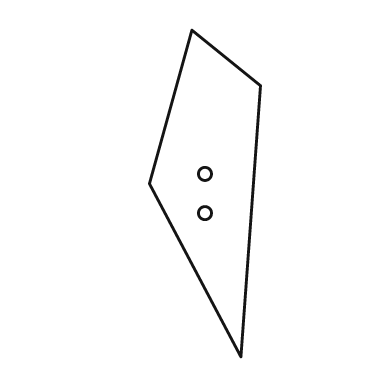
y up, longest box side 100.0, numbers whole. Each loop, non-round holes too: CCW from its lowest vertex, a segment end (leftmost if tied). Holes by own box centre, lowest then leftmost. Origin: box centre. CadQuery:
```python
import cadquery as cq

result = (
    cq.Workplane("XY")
    .moveTo(11.0, -50.0)
    .lineTo(17.0, 33.0)
    .lineTo(-4.0, 50.0)
    .lineTo(-17.0, 3.0)
    .close()
    .moveTo(0.0, -6.0)
    .circle(2.0)
    .moveTo(0.0, 6.0)
    .circle(2.0)
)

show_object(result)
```